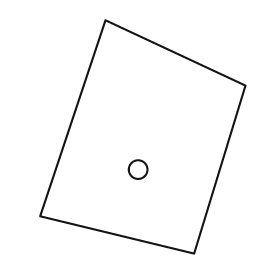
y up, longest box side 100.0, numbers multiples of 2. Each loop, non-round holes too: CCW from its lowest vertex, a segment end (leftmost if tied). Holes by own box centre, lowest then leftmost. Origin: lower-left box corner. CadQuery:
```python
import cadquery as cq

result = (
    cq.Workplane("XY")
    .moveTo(66.0, 0.0)
    .lineTo(88.0, 72.0)
    .lineTo(28.0, 100.0)
    .lineTo(0.0, 16.0)
    .close()
    .moveTo(42.0, 36.0)
    .circle(4.0)
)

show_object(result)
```